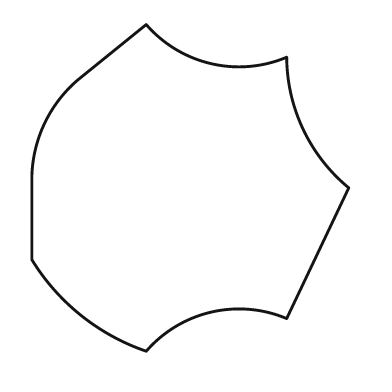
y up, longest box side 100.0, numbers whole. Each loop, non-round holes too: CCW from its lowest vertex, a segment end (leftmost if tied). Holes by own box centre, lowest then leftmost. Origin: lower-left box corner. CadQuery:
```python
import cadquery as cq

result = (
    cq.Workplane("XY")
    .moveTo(35.0, 0.0)
    .threePointArc((55.0, 12.0), (78.0, 10.0))
    .lineTo(97.0, 50.0)
    .threePointArc((83.0, 68.0), (78.0, 90.0))
    .threePointArc((55.0, 88.0), (35.0, 100.0))
    .lineTo(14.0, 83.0)
    .threePointArc((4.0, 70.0), (0.0, 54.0))
    .lineTo(0.0, 28.0)
    .threePointArc((15.0, 11.0), (35.0, 0.0))
    .close()
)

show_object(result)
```